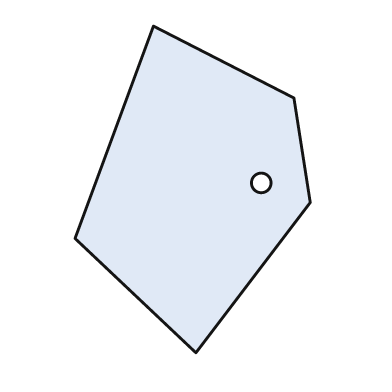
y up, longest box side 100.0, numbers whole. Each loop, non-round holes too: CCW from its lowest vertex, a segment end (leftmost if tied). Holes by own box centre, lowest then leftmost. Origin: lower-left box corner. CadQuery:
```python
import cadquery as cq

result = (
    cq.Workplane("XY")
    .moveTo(37.0, 0.0)
    .lineTo(72.0, 46.0)
    .lineTo(67.0, 78.0)
    .lineTo(24.0, 100.0)
    .lineTo(0.0, 35.0)
    .close()
    .moveTo(57.0, 52.0)
    .circle(3.0)
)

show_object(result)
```